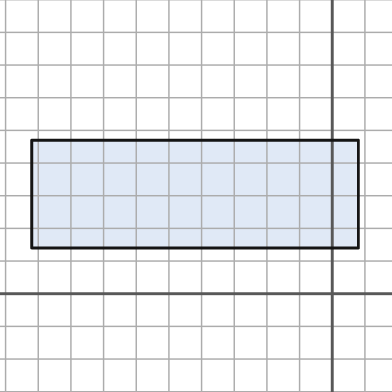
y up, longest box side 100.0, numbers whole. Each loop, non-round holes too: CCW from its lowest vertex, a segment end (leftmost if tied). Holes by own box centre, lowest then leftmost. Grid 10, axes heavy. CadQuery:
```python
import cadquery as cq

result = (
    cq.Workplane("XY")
    .moveTo(-92.0, 14.0)
    .lineTo(8.0, 14.0)
    .lineTo(8.0, 47.0)
    .lineTo(-92.0, 47.0)
    .close()
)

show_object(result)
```